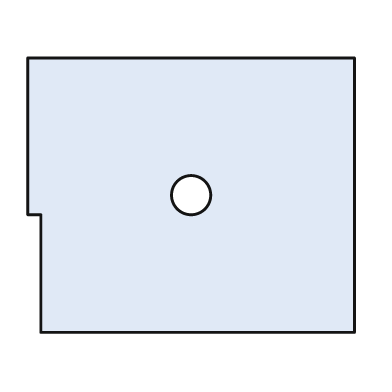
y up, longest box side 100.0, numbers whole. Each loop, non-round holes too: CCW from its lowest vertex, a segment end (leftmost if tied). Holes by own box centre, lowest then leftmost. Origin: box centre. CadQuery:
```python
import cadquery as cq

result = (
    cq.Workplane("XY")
    .moveTo(-46.0, -42.0)
    .lineTo(50.0, -42.0)
    .lineTo(50.0, 42.0)
    .lineTo(-50.0, 42.0)
    .lineTo(-50.0, -6.0)
    .lineTo(-46.0, -6.0)
    .close()
    .moveTo(0.0, 0.0)
    .circle(6.0)
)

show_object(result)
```